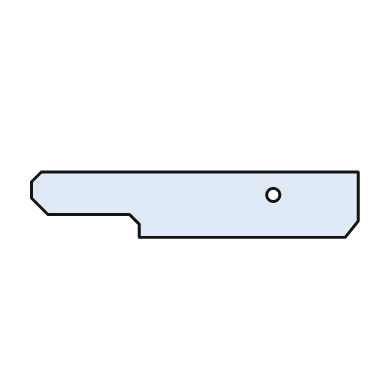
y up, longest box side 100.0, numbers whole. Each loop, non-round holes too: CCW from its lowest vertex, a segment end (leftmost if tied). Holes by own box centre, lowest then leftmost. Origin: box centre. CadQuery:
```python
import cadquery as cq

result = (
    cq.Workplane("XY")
    .moveTo(-17.0, -10.0)
    .lineTo(46.0, -10.0)
    .lineTo(50.0, -5.0)
    .lineTo(50.0, 10.0)
    .lineTo(-47.0, 10.0)
    .lineTo(-50.0, 7.0)
    .lineTo(-50.0, 2.0)
    .lineTo(-45.0, -3.0)
    .lineTo(-20.0, -3.0)
    .lineTo(-17.0, -6.0)
    .close()
    .moveTo(24.0, 3.0)
    .circle(2.0)
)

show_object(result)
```